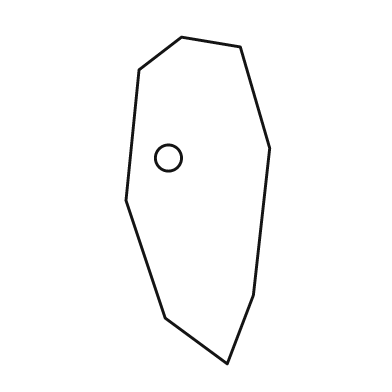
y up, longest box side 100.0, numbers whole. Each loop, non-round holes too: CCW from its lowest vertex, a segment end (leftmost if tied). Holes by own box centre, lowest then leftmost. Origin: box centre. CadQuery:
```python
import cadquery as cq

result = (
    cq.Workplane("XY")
    .moveTo(9.0, -50.0)
    .lineTo(17.0, -29.0)
    .lineTo(22.0, 16.0)
    .lineTo(13.0, 47.0)
    .lineTo(-5.0, 50.0)
    .lineTo(-18.0, 40.0)
    .lineTo(-22.0, 0.0)
    .lineTo(-10.0, -36.0)
    .close()
    .moveTo(-9.0, 13.0)
    .circle(4.0)
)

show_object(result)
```